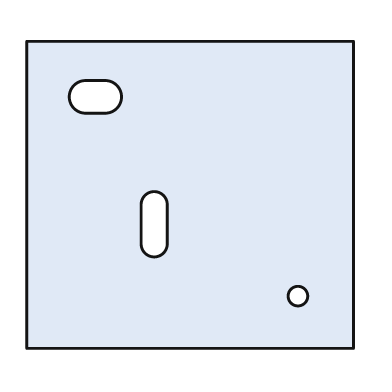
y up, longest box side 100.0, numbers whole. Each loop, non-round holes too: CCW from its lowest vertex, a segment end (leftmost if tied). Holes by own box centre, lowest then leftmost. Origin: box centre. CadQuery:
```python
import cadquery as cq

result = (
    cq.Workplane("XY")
    .moveTo(-50.0, -47.0)
    .lineTo(50.0, -47.0)
    .lineTo(50.0, 47.0)
    .lineTo(-50.0, 47.0)
    .close()
    .moveTo(33.0, -31.0)
    .circle(3.0)
    .moveTo(-15.0, -15.0)
    .threePointArc((-11.0, -19.0), (-7.0, -15.0))
    .lineTo(-7.0, -3.0)
    .threePointArc((-11.0, 1.0), (-15.0, -3.0))
    .close()
    .moveTo(-32.0, 25.0)
    .lineTo(-26.0, 25.0)
    .threePointArc((-21.0, 30.0), (-26.0, 35.0))
    .lineTo(-32.0, 35.0)
    .threePointArc((-37.0, 30.0), (-32.0, 25.0))
    .close()
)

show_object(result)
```